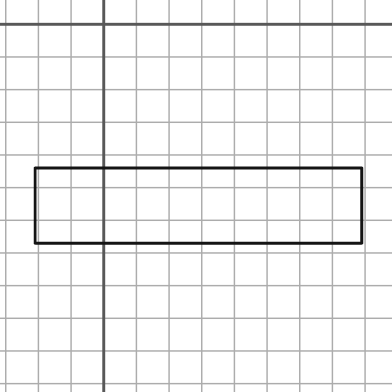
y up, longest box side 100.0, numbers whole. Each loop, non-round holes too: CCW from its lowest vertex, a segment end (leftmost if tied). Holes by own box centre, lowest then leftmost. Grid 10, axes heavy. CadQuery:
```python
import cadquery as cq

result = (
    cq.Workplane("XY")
    .moveTo(-21.0, -67.0)
    .lineTo(79.0, -67.0)
    .lineTo(79.0, -44.0)
    .lineTo(-21.0, -44.0)
    .close()
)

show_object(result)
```